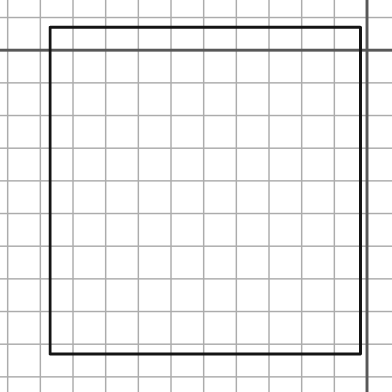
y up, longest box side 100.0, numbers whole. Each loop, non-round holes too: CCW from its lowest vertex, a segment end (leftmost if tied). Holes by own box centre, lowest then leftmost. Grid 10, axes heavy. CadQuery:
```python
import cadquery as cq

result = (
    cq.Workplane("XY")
    .moveTo(-97.0, -93.0)
    .lineTo(-2.0, -93.0)
    .lineTo(-2.0, 7.0)
    .lineTo(-97.0, 7.0)
    .close()
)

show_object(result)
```